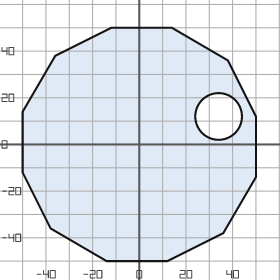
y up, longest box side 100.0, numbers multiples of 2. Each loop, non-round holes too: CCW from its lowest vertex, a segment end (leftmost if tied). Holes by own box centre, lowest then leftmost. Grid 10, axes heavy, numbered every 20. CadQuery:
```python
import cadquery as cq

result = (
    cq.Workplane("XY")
    .moveTo(-14.0, -50.0)
    .lineTo(12.0, -50.0)
    .lineTo(36.0, -38.0)
    .lineTo(50.0, -14.0)
    .lineTo(50.0, 12.0)
    .lineTo(38.0, 36.0)
    .lineTo(14.0, 50.0)
    .lineTo(-12.0, 50.0)
    .lineTo(-36.0, 38.0)
    .lineTo(-50.0, 14.0)
    .lineTo(-50.0, -12.0)
    .lineTo(-38.0, -36.0)
    .close()
    .moveTo(34.0, 12.0)
    .circle(10.0)
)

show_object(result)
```